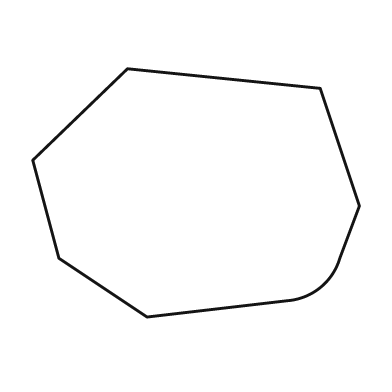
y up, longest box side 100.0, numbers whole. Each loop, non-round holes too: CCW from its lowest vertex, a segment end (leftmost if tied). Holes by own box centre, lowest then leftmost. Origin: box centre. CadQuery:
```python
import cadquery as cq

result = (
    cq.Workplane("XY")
    .moveTo(-15.0, -38.0)
    .lineTo(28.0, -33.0)
    .threePointArc((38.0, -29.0), (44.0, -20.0))
    .lineTo(50.0, -4.0)
    .lineTo(38.0, 32.0)
    .lineTo(-21.0, 38.0)
    .lineTo(-50.0, 10.0)
    .lineTo(-42.0, -20.0)
    .close()
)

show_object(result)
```